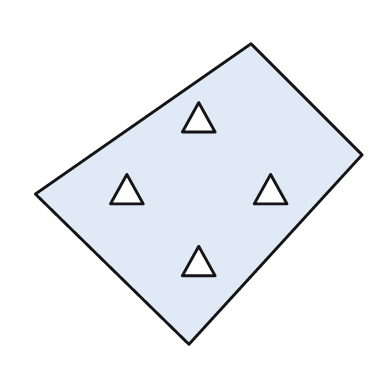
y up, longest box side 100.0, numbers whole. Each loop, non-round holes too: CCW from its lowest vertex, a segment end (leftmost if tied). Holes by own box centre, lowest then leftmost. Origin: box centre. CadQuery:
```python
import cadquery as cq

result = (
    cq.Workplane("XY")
    .moveTo(-3.0, -46.0)
    .lineTo(50.0, 12.0)
    .lineTo(16.0, 46.0)
    .lineTo(-50.0, 0.0)
    .close()
    .moveTo(-5.0, -25.0)
    .lineTo(5.0, -25.0)
    .lineTo(0.0, -16.0)
    .close()
    .moveTo(-27.0, -3.0)
    .lineTo(-17.0, -3.0)
    .lineTo(-22.0, 6.0)
    .close()
    .moveTo(17.0, -3.0)
    .lineTo(27.0, -3.0)
    .lineTo(22.0, 6.0)
    .close()
    .moveTo(-5.0, 19.0)
    .lineTo(5.0, 19.0)
    .lineTo(0.0, 28.0)
    .close()
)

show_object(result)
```